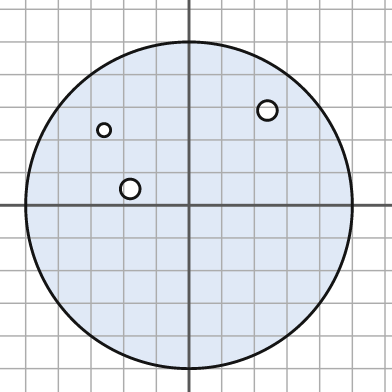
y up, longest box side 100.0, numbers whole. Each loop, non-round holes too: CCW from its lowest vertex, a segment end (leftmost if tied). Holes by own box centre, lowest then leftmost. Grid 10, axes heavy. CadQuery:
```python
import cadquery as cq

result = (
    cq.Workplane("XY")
    .moveTo(0.0, 0.0)
    .circle(50.0)
    .moveTo(-18.0, 5.0)
    .circle(3.0)
    .moveTo(-26.0, 23.0)
    .circle(2.0)
    .moveTo(24.0, 29.0)
    .circle(3.0)
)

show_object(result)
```